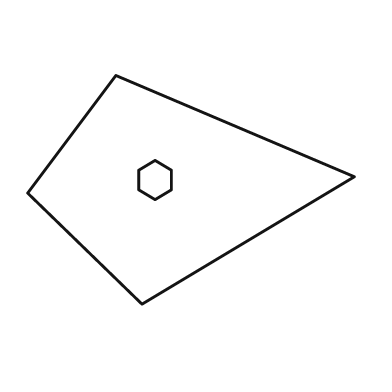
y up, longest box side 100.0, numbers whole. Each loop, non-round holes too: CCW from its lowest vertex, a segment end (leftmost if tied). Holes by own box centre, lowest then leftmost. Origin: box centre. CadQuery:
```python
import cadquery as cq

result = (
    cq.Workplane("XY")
    .moveTo(-15.0, -35.0)
    .lineTo(50.0, 4.0)
    .lineTo(-23.0, 35.0)
    .lineTo(-50.0, -1.0)
    .close()
    .moveTo(-11.0, -3.0)
    .lineTo(-6.0, 0.0)
    .lineTo(-6.0, 6.0)
    .lineTo(-11.0, 9.0)
    .lineTo(-16.0, 6.0)
    .lineTo(-16.0, 0.0)
    .close()
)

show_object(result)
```